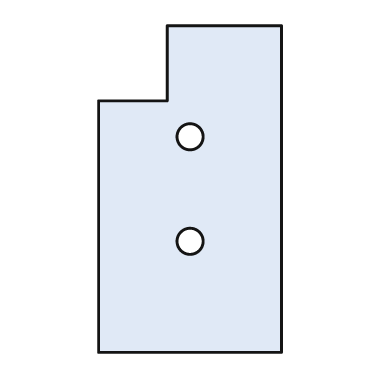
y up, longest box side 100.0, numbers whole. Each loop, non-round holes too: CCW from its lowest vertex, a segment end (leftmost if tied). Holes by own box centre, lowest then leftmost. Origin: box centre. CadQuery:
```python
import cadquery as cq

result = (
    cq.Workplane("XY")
    .moveTo(-28.0, -50.0)
    .lineTo(28.0, -50.0)
    .lineTo(28.0, 50.0)
    .lineTo(-7.0, 50.0)
    .lineTo(-7.0, 27.0)
    .lineTo(-28.0, 27.0)
    .close()
    .moveTo(0.0, -16.0)
    .circle(4.0)
    .moveTo(0.0, 16.0)
    .circle(4.0)
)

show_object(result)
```